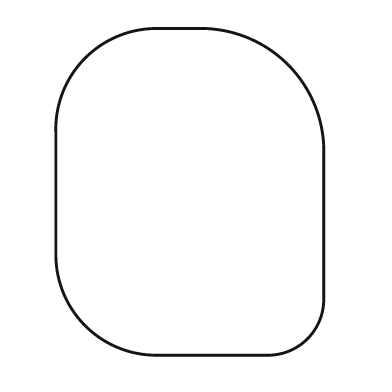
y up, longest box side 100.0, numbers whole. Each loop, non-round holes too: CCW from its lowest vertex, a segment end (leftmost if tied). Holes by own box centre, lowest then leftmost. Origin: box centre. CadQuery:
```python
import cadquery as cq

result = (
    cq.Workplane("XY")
    .moveTo(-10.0, -50.0)
    .lineTo(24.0, -50.0)
    .threePointArc((36.0, -45.0), (41.0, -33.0))
    .lineTo(41.0, 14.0)
    .threePointArc((30.0, 39.0), (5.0, 50.0))
    .lineTo(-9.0, 50.0)
    .threePointArc((-32.0, 41.0), (-41.0, 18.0))
    .lineTo(-41.0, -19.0)
    .threePointArc((-32.0, -41.0), (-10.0, -50.0))
    .close()
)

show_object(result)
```